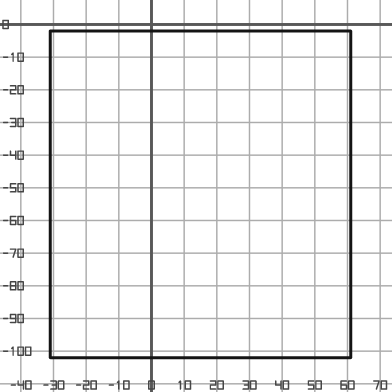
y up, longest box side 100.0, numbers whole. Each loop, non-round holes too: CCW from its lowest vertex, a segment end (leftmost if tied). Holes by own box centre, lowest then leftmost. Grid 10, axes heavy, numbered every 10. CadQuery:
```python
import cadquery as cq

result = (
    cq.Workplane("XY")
    .moveTo(-31.0, -102.0)
    .lineTo(61.0, -102.0)
    .lineTo(61.0, -2.0)
    .lineTo(-31.0, -2.0)
    .close()
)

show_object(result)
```